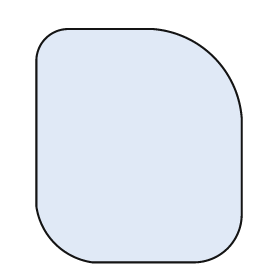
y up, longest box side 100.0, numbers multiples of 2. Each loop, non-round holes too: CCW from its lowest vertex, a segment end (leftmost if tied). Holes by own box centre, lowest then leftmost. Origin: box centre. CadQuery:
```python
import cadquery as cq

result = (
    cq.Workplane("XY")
    .moveTo(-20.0, -50.0)
    .lineTo(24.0, -50.0)
    .threePointArc((38.0, -44.0), (44.0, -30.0))
    .lineTo(44.0, 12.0)
    .threePointArc((32.0, 38.0), (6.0, 50.0))
    .lineTo(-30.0, 50.0)
    .threePointArc((-40.0, 46.0), (-44.0, 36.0))
    .lineTo(-44.0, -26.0)
    .threePointArc((-36.0, -42.0), (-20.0, -50.0))
    .close()
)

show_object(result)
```